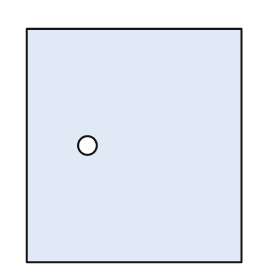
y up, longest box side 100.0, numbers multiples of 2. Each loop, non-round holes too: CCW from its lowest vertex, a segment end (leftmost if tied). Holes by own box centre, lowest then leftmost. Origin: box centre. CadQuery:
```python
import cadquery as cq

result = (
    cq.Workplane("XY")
    .moveTo(-46.0, -50.0)
    .lineTo(46.0, -50.0)
    .lineTo(46.0, 50.0)
    .lineTo(-46.0, 50.0)
    .close()
    .moveTo(-20.0, 0.0)
    .circle(4.0)
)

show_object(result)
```